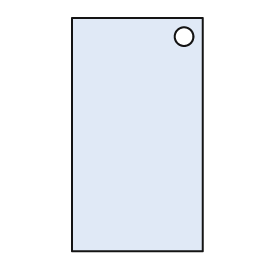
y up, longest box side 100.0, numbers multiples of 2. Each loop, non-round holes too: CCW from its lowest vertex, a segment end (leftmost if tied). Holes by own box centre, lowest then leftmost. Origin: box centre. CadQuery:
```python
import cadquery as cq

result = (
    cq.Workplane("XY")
    .moveTo(-28.0, -50.0)
    .lineTo(28.0, -50.0)
    .lineTo(28.0, 50.0)
    .lineTo(-28.0, 50.0)
    .close()
    .moveTo(20.0, 42.0)
    .circle(4.0)
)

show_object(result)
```